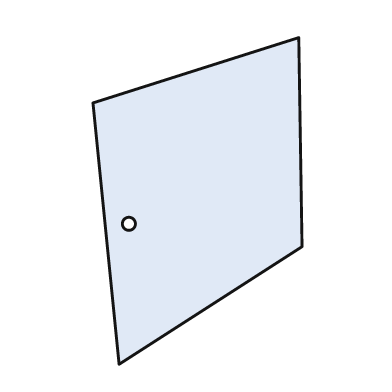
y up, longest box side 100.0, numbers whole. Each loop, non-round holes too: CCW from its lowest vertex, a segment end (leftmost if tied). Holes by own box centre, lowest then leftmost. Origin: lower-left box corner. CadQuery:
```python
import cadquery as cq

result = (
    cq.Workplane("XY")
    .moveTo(8.0, 0.0)
    .lineTo(64.0, 36.0)
    .lineTo(63.0, 100.0)
    .lineTo(0.0, 80.0)
    .close()
    .moveTo(11.0, 43.0)
    .circle(2.0)
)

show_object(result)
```